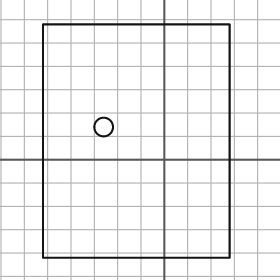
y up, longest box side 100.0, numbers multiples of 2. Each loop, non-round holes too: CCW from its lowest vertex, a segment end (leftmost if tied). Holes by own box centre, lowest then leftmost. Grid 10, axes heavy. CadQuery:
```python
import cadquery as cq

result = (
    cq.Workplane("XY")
    .moveTo(-52.0, -42.0)
    .lineTo(28.0, -42.0)
    .lineTo(28.0, 58.0)
    .lineTo(-52.0, 58.0)
    .close()
    .moveTo(-26.0, 14.0)
    .circle(4.0)
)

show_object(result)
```